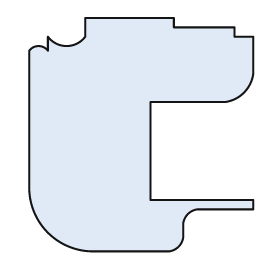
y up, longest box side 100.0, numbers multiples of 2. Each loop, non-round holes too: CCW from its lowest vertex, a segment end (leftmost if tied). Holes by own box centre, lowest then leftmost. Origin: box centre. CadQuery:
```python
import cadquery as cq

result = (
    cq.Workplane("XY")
    .moveTo(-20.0, -50.0)
    .lineTo(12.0, -50.0)
    .threePointArc((16.0, -48.0), (18.0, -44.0))
    .lineTo(18.0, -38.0)
    .threePointArc((20.0, -34.0), (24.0, -32.0))
    .lineTo(48.0, -32.0)
    .lineTo(48.0, -28.0)
    .lineTo(4.0, -28.0)
    .lineTo(4.0, 14.0)
    .lineTo(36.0, 14.0)
    .threePointArc((44.0, 18.0), (48.0, 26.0))
    .lineTo(48.0, 42.0)
    .lineTo(40.0, 42.0)
    .lineTo(40.0, 46.0)
    .lineTo(14.0, 46.0)
    .lineTo(14.0, 50.0)
    .lineTo(-24.0, 50.0)
    .lineTo(-24.0, 42.0)
    .threePointArc((-32.0, 38.0), (-40.0, 42.0))
    .lineTo(-40.0, 36.0)
    .threePointArc((-44.0, 38.0), (-48.0, 36.0))
    .lineTo(-48.0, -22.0)
    .threePointArc((-40.0, -42.0), (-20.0, -50.0))
    .close()
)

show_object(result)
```